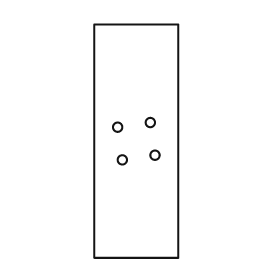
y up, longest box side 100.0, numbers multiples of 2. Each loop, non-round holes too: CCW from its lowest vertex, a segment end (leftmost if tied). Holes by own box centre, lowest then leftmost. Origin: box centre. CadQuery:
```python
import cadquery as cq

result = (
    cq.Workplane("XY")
    .moveTo(-18.0, -50.0)
    .lineTo(18.0, -50.0)
    .lineTo(18.0, 50.0)
    .lineTo(-18.0, 50.0)
    .close()
    .moveTo(-6.0, -8.0)
    .circle(2.0)
    .moveTo(8.0, -6.0)
    .circle(2.0)
    .moveTo(-8.0, 6.0)
    .circle(2.0)
    .moveTo(6.0, 8.0)
    .circle(2.0)
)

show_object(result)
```